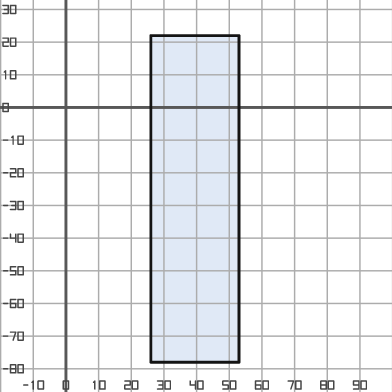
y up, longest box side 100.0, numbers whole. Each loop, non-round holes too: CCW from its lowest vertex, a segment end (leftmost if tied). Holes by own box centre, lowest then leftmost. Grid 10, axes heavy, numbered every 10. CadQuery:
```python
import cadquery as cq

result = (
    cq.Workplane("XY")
    .moveTo(26.0, -78.0)
    .lineTo(53.0, -78.0)
    .lineTo(53.0, 22.0)
    .lineTo(26.0, 22.0)
    .close()
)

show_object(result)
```